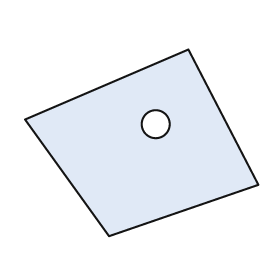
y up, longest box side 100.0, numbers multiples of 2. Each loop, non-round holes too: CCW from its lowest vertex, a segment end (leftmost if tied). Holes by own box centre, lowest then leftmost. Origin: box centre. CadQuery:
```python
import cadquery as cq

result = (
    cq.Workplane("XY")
    .moveTo(-14.0, -40.0)
    .lineTo(50.0, -18.0)
    .lineTo(20.0, 40.0)
    .lineTo(-50.0, 10.0)
    .close()
    .moveTo(6.0, 8.0)
    .circle(6.0)
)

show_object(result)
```